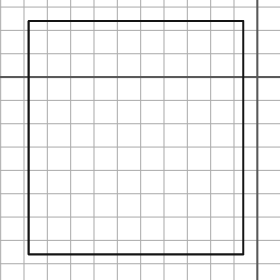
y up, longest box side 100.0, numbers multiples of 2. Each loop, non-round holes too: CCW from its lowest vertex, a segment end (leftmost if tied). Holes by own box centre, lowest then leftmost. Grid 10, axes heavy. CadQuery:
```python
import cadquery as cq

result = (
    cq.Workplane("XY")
    .moveTo(-98.0, -76.0)
    .lineTo(-6.0, -76.0)
    .lineTo(-6.0, 24.0)
    .lineTo(-98.0, 24.0)
    .close()
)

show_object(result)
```